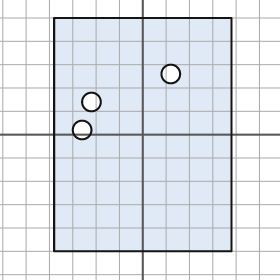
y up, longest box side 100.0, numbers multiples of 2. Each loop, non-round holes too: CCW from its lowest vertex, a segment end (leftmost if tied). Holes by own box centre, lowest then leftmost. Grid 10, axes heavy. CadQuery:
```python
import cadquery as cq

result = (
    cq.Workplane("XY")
    .moveTo(-38.0, -50.0)
    .lineTo(38.0, -50.0)
    .lineTo(38.0, 50.0)
    .lineTo(-38.0, 50.0)
    .close()
    .moveTo(-26.0, 2.0)
    .circle(4.0)
    .moveTo(-22.0, 14.0)
    .circle(4.0)
    .moveTo(12.0, 26.0)
    .circle(4.0)
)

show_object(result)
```